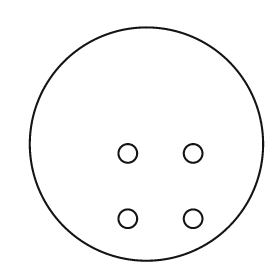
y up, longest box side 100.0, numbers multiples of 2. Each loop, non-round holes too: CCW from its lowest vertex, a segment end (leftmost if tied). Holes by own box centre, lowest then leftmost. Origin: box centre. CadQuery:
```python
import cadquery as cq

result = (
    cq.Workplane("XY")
    .moveTo(0.0, 0.0)
    .circle(50.0)
    .moveTo(-8.0, -32.0)
    .circle(4.0)
    .moveTo(20.0, -32.0)
    .circle(4.0)
    .moveTo(-8.0, -4.0)
    .circle(4.0)
    .moveTo(20.0, -4.0)
    .circle(4.0)
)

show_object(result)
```